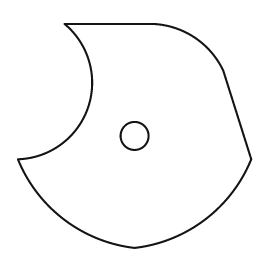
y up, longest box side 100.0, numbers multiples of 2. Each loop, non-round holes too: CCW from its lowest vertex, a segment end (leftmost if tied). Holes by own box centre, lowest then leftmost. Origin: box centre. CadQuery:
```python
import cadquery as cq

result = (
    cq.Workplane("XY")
    .moveTo(0.0, -48.0)
    .threePointArc((30.0, -36.0), (50.0, -10.0))
    .lineTo(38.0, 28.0)
    .threePointArc((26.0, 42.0), (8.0, 48.0))
    .lineTo(-30.0, 48.0)
    .threePointArc((-20.0, 12.0), (-50.0, -10.0))
    .threePointArc((-30.0, -36.0), (0.0, -48.0))
    .close()
    .moveTo(0.0, 0.0)
    .circle(6.0)
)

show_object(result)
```